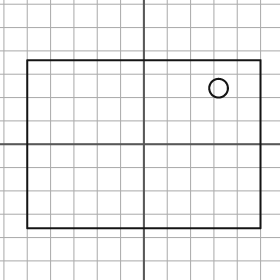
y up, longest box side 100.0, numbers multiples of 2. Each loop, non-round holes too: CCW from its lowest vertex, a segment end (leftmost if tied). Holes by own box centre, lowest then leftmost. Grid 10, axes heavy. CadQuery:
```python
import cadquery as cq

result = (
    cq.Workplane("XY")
    .moveTo(-50.0, -36.0)
    .lineTo(50.0, -36.0)
    .lineTo(50.0, 36.0)
    .lineTo(-50.0, 36.0)
    .close()
    .moveTo(32.0, 24.0)
    .circle(4.0)
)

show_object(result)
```